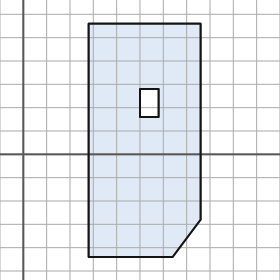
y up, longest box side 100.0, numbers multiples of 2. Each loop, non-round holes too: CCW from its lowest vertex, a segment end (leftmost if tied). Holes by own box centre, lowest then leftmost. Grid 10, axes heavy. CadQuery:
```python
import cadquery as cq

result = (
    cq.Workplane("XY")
    .moveTo(28.0, -44.0)
    .lineTo(64.0, -44.0)
    .lineTo(76.0, -28.0)
    .lineTo(76.0, 56.0)
    .lineTo(28.0, 56.0)
    .close()
    .moveTo(50.0, 16.0)
    .lineTo(58.0, 16.0)
    .lineTo(58.0, 28.0)
    .lineTo(50.0, 28.0)
    .close()
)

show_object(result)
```